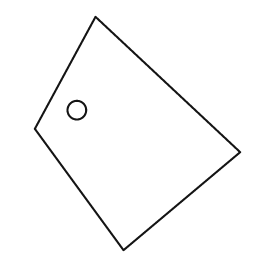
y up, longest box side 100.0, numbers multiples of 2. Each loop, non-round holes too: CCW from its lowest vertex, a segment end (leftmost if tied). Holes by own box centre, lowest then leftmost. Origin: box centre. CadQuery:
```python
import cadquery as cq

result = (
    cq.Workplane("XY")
    .moveTo(-6.0, -50.0)
    .lineTo(44.0, -8.0)
    .lineTo(-18.0, 50.0)
    .lineTo(-44.0, 2.0)
    .close()
    .moveTo(-26.0, 10.0)
    .circle(4.0)
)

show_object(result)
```